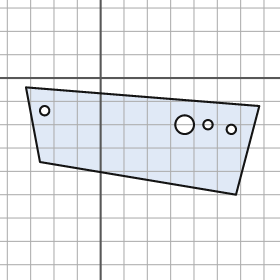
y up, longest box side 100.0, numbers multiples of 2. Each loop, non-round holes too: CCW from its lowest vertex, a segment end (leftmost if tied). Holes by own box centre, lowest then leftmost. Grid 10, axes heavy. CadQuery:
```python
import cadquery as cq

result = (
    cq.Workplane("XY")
    .moveTo(58.0, -50.0)
    .lineTo(68.0, -12.0)
    .lineTo(-32.0, -4.0)
    .lineTo(-26.0, -36.0)
    .close()
    .moveTo(56.0, -22.0)
    .circle(2.0)
    .moveTo(36.0, -20.0)
    .circle(4.0)
    .moveTo(46.0, -20.0)
    .circle(2.0)
    .moveTo(-24.0, -14.0)
    .circle(2.0)
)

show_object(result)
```